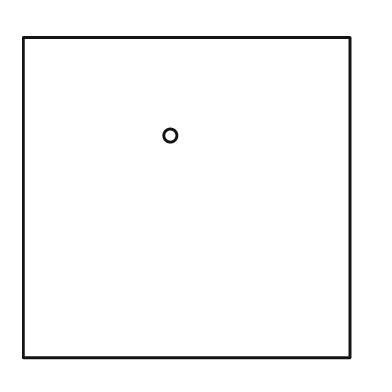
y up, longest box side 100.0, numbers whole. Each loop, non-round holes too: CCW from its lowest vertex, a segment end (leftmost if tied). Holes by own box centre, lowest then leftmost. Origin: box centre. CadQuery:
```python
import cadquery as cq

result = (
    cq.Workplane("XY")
    .moveTo(-50.0, -49.0)
    .lineTo(50.0, -49.0)
    .lineTo(50.0, 49.0)
    .lineTo(-50.0, 49.0)
    .close()
    .moveTo(-5.0, 19.0)
    .circle(2.0)
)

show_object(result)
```